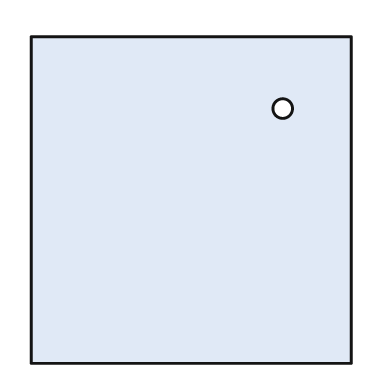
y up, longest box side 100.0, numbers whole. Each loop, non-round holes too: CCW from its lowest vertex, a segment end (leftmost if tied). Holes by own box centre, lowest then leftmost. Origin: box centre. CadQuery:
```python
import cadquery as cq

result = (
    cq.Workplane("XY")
    .moveTo(-49.0, -50.0)
    .lineTo(49.0, -50.0)
    .lineTo(49.0, 50.0)
    .lineTo(-49.0, 50.0)
    .close()
    .moveTo(28.0, 28.0)
    .circle(3.0)
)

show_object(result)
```